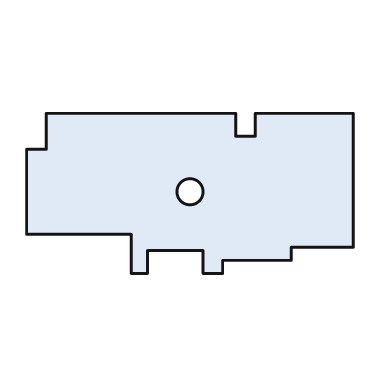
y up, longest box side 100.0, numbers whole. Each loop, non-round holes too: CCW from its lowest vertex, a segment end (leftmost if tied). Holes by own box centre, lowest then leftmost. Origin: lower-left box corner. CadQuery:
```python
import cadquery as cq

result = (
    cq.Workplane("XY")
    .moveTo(32.0, 0.0)
    .lineTo(37.0, 0.0)
    .lineTo(37.0, 7.0)
    .lineTo(54.0, 7.0)
    .lineTo(54.0, 0.0)
    .lineTo(60.0, 0.0)
    .lineTo(60.0, 4.0)
    .lineTo(81.0, 4.0)
    .lineTo(81.0, 8.0)
    .lineTo(100.0, 8.0)
    .lineTo(100.0, 49.0)
    .lineTo(70.0, 49.0)
    .lineTo(70.0, 42.0)
    .lineTo(64.0, 42.0)
    .lineTo(64.0, 49.0)
    .lineTo(6.0, 49.0)
    .lineTo(6.0, 38.0)
    .lineTo(0.0, 38.0)
    .lineTo(0.0, 12.0)
    .lineTo(32.0, 12.0)
    .close()
    .moveTo(50.0, 25.0)
    .circle(4.0)
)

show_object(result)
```